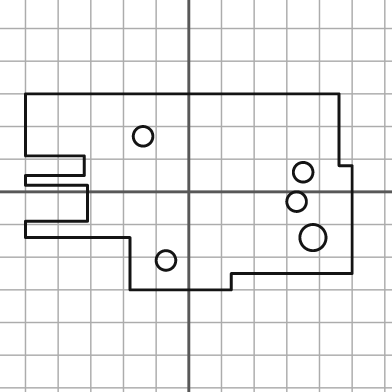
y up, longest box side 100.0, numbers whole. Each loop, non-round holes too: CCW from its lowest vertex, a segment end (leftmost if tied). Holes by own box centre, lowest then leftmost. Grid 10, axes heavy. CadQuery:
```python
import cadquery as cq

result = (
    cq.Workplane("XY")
    .moveTo(-18.0, -30.0)
    .lineTo(13.0, -30.0)
    .lineTo(13.0, -25.0)
    .lineTo(50.0, -25.0)
    .lineTo(50.0, 8.0)
    .lineTo(46.0, 8.0)
    .lineTo(46.0, 30.0)
    .lineTo(-50.0, 30.0)
    .lineTo(-50.0, 11.0)
    .lineTo(-32.0, 11.0)
    .lineTo(-32.0, 5.0)
    .lineTo(-50.0, 5.0)
    .lineTo(-50.0, 2.0)
    .lineTo(-31.0, 2.0)
    .lineTo(-31.0, -9.0)
    .lineTo(-50.0, -9.0)
    .lineTo(-50.0, -14.0)
    .lineTo(-18.0, -14.0)
    .close()
    .moveTo(-7.0, -21.0)
    .circle(3.0)
    .moveTo(38.0, -14.0)
    .circle(4.0)
    .moveTo(33.0, -3.0)
    .circle(3.0)
    .moveTo(35.0, 6.0)
    .circle(3.0)
    .moveTo(-14.0, 17.0)
    .circle(3.0)
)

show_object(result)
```